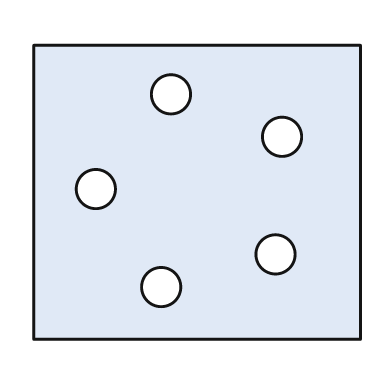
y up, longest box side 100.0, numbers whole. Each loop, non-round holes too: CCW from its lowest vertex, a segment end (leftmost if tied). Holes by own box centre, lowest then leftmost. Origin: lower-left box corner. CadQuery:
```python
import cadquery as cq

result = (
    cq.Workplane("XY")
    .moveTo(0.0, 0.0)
    .lineTo(100.0, 0.0)
    .lineTo(100.0, 90.0)
    .lineTo(0.0, 90.0)
    .close()
    .moveTo(39.0, 16.0)
    .circle(6.0)
    .moveTo(74.0, 26.0)
    .circle(6.0)
    .moveTo(19.0, 46.0)
    .circle(6.0)
    .moveTo(76.0, 62.0)
    .circle(6.0)
    .moveTo(42.0, 75.0)
    .circle(6.0)
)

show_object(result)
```